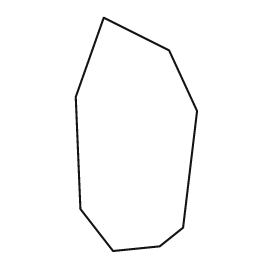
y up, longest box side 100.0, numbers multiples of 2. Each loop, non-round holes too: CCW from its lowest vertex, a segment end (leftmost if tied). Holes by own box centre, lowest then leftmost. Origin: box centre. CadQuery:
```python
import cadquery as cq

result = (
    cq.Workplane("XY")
    .moveTo(-10.0, -50.0)
    .lineTo(10.0, -48.0)
    .lineTo(20.0, -40.0)
    .lineTo(26.0, 10.0)
    .lineTo(14.0, 36.0)
    .lineTo(-14.0, 50.0)
    .lineTo(-26.0, 16.0)
    .lineTo(-24.0, -32.0)
    .close()
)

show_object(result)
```